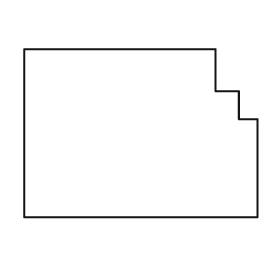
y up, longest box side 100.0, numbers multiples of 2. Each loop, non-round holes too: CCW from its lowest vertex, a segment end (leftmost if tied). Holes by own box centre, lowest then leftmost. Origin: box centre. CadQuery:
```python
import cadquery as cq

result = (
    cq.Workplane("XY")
    .moveTo(-50.0, -36.0)
    .lineTo(50.0, -36.0)
    .lineTo(50.0, 6.0)
    .lineTo(42.0, 6.0)
    .lineTo(42.0, 18.0)
    .lineTo(32.0, 18.0)
    .lineTo(32.0, 36.0)
    .lineTo(-50.0, 36.0)
    .close()
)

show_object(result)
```